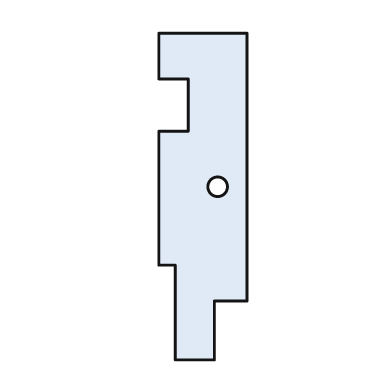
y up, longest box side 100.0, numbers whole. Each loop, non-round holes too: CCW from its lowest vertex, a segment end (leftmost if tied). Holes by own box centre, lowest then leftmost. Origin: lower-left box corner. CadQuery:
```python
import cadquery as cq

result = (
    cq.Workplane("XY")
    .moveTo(5.0, 0.0)
    .lineTo(17.0, 0.0)
    .lineTo(17.0, 18.0)
    .lineTo(27.0, 18.0)
    .lineTo(27.0, 100.0)
    .lineTo(0.0, 100.0)
    .lineTo(0.0, 86.0)
    .lineTo(9.0, 86.0)
    .lineTo(9.0, 70.0)
    .lineTo(0.0, 70.0)
    .lineTo(0.0, 29.0)
    .lineTo(5.0, 29.0)
    .close()
    .moveTo(18.0, 53.0)
    .circle(3.0)
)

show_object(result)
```